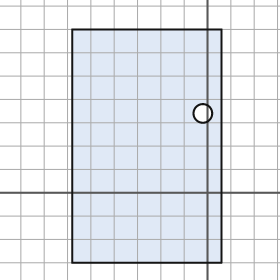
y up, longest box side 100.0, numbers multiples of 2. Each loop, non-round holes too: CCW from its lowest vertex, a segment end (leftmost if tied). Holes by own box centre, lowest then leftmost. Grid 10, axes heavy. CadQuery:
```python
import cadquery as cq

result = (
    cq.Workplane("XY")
    .moveTo(-58.0, -30.0)
    .lineTo(6.0, -30.0)
    .lineTo(6.0, 70.0)
    .lineTo(-58.0, 70.0)
    .close()
    .moveTo(-2.0, 34.0)
    .circle(4.0)
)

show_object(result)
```